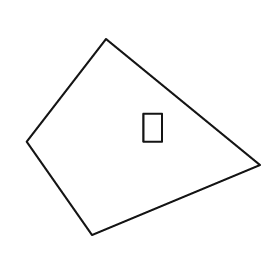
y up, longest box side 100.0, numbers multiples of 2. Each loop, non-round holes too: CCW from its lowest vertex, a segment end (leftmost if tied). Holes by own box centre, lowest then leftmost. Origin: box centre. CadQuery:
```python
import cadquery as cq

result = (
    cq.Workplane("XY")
    .moveTo(-22.0, -42.0)
    .lineTo(50.0, -12.0)
    .lineTo(-16.0, 42.0)
    .lineTo(-50.0, -2.0)
    .close()
    .moveTo(0.0, -2.0)
    .lineTo(8.0, -2.0)
    .lineTo(8.0, 10.0)
    .lineTo(0.0, 10.0)
    .close()
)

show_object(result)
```